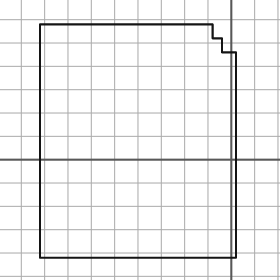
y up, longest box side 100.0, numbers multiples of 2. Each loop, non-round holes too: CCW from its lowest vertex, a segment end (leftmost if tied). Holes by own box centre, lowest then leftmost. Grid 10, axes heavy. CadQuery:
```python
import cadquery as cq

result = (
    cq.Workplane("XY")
    .moveTo(-82.0, -42.0)
    .lineTo(2.0, -42.0)
    .lineTo(2.0, 46.0)
    .lineTo(-4.0, 46.0)
    .lineTo(-4.0, 52.0)
    .lineTo(-8.0, 52.0)
    .lineTo(-8.0, 58.0)
    .lineTo(-82.0, 58.0)
    .close()
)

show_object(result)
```